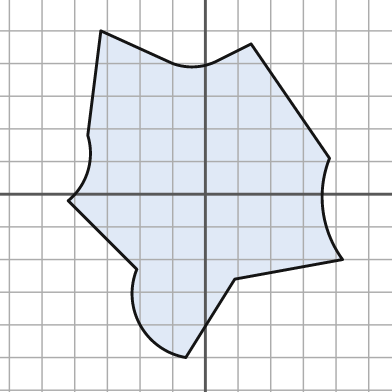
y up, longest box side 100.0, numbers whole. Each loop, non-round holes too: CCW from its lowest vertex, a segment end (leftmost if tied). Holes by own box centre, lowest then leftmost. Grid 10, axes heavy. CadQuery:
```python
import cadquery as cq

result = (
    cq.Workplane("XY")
    .moveTo(-6.0, -50.0)
    .lineTo(9.0, -26.0)
    .lineTo(42.0, -20.0)
    .threePointArc((36.0, -5.0), (38.0, 11.0))
    .lineTo(14.0, 46.0)
    .lineTo(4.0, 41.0)
    .threePointArc((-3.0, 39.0), (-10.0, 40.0))
    .lineTo(-32.0, 50.0)
    .lineTo(-36.0, 18.0)
    .threePointArc((-36.0, 7.0), (-42.0, -2.0))
    .lineTo(-21.0, -23.0)
    .threePointArc((-20.0, -40.0), (-6.0, -50.0))
    .close()
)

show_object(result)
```